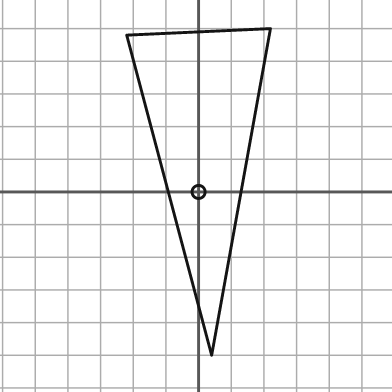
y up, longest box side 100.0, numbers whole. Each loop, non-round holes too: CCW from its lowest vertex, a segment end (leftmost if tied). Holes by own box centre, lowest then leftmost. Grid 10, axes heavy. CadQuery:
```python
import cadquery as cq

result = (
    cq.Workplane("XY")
    .moveTo(4.0, -50.0)
    .lineTo(22.0, 50.0)
    .lineTo(-22.0, 48.0)
    .close()
    .moveTo(0.0, 0.0)
    .circle(2.0)
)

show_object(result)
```